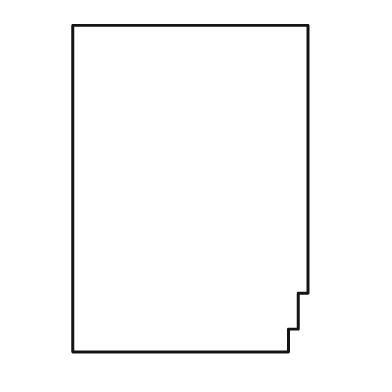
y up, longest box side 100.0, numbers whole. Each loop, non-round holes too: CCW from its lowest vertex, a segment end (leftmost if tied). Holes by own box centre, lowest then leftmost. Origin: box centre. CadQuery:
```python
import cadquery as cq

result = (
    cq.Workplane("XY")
    .moveTo(-36.0, -50.0)
    .lineTo(30.0, -50.0)
    .lineTo(30.0, -43.0)
    .lineTo(33.0, -43.0)
    .lineTo(33.0, -32.0)
    .lineTo(36.0, -32.0)
    .lineTo(36.0, 50.0)
    .lineTo(-36.0, 50.0)
    .close()
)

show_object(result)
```